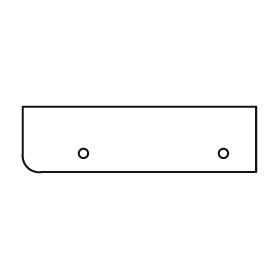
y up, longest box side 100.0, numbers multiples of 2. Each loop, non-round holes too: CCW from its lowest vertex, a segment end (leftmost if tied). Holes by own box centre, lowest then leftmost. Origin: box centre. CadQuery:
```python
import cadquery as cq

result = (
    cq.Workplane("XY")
    .moveTo(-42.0, -14.0)
    .lineTo(50.0, -14.0)
    .lineTo(50.0, 14.0)
    .lineTo(-50.0, 14.0)
    .lineTo(-50.0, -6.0)
    .threePointArc((-48.0, -12.0), (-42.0, -14.0))
    .close()
    .moveTo(-24.0, -6.0)
    .circle(2.0)
    .moveTo(36.0, -6.0)
    .circle(2.0)
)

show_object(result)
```